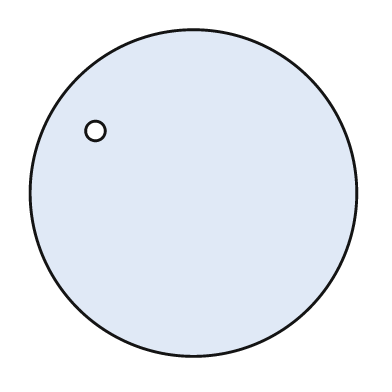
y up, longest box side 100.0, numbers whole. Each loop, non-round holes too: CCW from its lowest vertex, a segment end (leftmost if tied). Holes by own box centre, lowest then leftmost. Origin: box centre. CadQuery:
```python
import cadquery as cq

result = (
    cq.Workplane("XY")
    .moveTo(0.0, 0.0)
    .circle(50.0)
    .moveTo(-30.0, 19.0)
    .circle(3.0)
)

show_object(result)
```